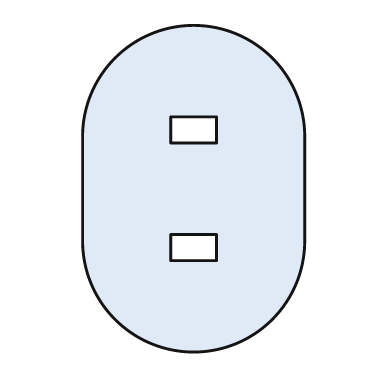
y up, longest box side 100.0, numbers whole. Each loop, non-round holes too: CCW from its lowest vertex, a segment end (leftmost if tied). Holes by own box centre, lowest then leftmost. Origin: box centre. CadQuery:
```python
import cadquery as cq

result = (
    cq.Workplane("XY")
    .moveTo(-34.0, -16.0)
    .threePointArc((0.0, -50.0), (34.0, -16.0))
    .lineTo(34.0, 16.0)
    .threePointArc((0.0, 50.0), (-34.0, 16.0))
    .close()
    .moveTo(-7.0, -22.0)
    .lineTo(7.0, -22.0)
    .lineTo(7.0, -14.0)
    .lineTo(-7.0, -14.0)
    .close()
    .moveTo(-7.0, 14.0)
    .lineTo(7.0, 14.0)
    .lineTo(7.0, 22.0)
    .lineTo(-7.0, 22.0)
    .close()
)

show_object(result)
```